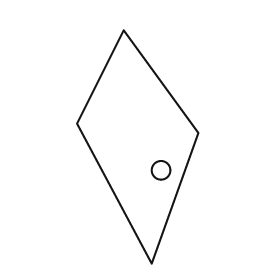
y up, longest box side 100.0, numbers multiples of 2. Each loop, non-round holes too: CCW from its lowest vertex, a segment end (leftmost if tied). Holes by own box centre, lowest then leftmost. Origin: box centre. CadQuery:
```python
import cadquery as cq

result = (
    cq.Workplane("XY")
    .moveTo(6.0, -50.0)
    .lineTo(26.0, 6.0)
    .lineTo(-6.0, 50.0)
    .lineTo(-26.0, 10.0)
    .close()
    .moveTo(10.0, -10.0)
    .circle(4.0)
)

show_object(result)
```